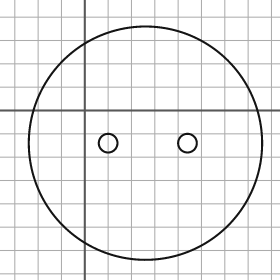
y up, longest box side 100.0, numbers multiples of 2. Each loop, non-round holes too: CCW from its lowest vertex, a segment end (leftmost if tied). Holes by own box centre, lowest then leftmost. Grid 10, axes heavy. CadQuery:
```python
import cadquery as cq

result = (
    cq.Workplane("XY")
    .moveTo(26.0, -14.0)
    .circle(50.0)
    .moveTo(10.0, -14.0)
    .circle(4.0)
    .moveTo(44.0, -14.0)
    .circle(4.0)
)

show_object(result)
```